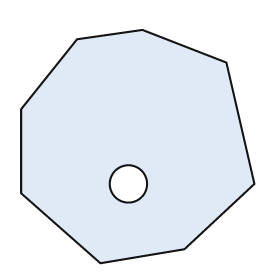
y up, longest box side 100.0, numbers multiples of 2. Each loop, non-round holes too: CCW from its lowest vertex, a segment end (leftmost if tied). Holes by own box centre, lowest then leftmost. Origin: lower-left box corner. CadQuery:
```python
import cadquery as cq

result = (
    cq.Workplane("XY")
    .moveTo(34.0, 0.0)
    .lineTo(70.0, 6.0)
    .lineTo(100.0, 34.0)
    .lineTo(88.0, 86.0)
    .lineTo(52.0, 100.0)
    .lineTo(24.0, 96.0)
    .lineTo(0.0, 66.0)
    .lineTo(0.0, 30.0)
    .close()
    .moveTo(46.0, 34.0)
    .circle(8.0)
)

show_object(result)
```